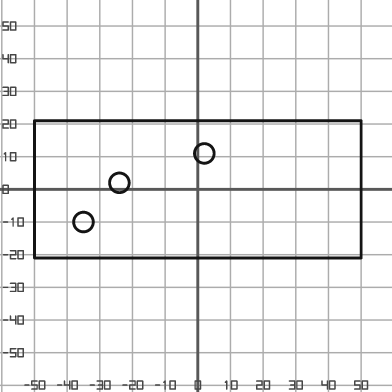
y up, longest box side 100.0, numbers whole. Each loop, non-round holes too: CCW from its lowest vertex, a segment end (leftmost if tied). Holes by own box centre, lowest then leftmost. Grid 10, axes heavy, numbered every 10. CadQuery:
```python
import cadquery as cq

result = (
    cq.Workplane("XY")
    .moveTo(-50.0, -21.0)
    .lineTo(50.0, -21.0)
    .lineTo(50.0, 21.0)
    .lineTo(-50.0, 21.0)
    .close()
    .moveTo(-35.0, -10.0)
    .circle(3.0)
    .moveTo(-24.0, 2.0)
    .circle(3.0)
    .moveTo(2.0, 11.0)
    .circle(3.0)
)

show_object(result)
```